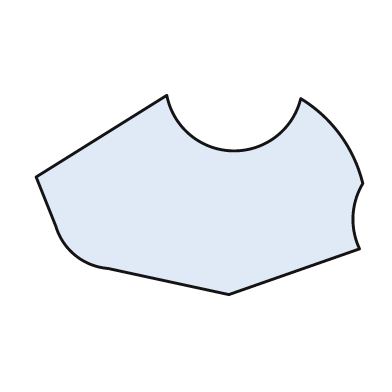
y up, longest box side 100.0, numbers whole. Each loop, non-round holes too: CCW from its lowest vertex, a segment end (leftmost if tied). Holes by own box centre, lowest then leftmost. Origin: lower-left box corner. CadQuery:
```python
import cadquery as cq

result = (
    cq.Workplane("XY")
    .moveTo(59.0, 0.0)
    .lineTo(99.0, 14.0)
    .threePointArc((97.0, 24.0), (100.0, 34.0))
    .threePointArc((93.0, 49.0), (81.0, 60.0))
    .threePointArc((60.0, 44.0), (40.0, 61.0))
    .lineTo(0.0, 36.0)
    .lineTo(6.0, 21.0)
    .threePointArc((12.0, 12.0), (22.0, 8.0))
    .close()
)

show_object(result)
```